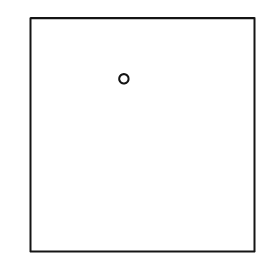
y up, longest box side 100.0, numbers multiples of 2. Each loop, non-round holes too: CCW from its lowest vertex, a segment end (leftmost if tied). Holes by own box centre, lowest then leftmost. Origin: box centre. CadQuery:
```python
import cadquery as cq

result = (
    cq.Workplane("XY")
    .moveTo(-48.0, -50.0)
    .lineTo(48.0, -50.0)
    .lineTo(48.0, 50.0)
    .lineTo(-48.0, 50.0)
    .close()
    .moveTo(-8.0, 24.0)
    .circle(2.0)
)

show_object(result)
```